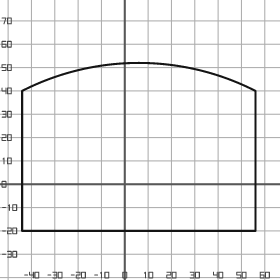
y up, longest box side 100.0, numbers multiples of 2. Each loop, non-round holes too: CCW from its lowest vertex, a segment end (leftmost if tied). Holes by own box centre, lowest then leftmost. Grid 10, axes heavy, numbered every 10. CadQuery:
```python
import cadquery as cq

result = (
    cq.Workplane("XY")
    .moveTo(-44.0, -20.0)
    .lineTo(56.0, -20.0)
    .lineTo(56.0, 40.0)
    .threePointArc((6.0, 52.0), (-44.0, 40.0))
    .close()
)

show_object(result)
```